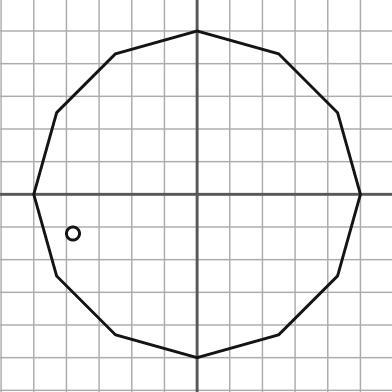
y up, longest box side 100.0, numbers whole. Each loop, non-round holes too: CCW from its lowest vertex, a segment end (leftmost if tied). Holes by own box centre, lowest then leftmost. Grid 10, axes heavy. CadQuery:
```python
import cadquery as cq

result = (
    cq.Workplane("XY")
    .moveTo(0.0, -50.0)
    .lineTo(25.0, -43.0)
    .lineTo(43.0, -25.0)
    .lineTo(50.0, 0.0)
    .lineTo(43.0, 25.0)
    .lineTo(25.0, 43.0)
    .lineTo(0.0, 50.0)
    .lineTo(-25.0, 43.0)
    .lineTo(-43.0, 25.0)
    .lineTo(-50.0, 0.0)
    .lineTo(-43.0, -25.0)
    .lineTo(-25.0, -43.0)
    .close()
    .moveTo(-38.0, -12.0)
    .circle(2.0)
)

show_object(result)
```